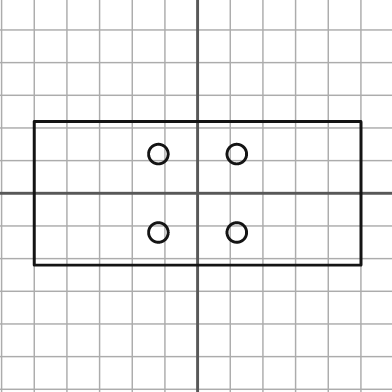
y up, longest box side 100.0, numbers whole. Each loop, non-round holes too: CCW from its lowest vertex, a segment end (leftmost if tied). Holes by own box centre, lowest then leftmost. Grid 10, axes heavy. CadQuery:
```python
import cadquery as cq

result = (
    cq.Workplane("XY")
    .moveTo(-50.0, -22.0)
    .lineTo(50.0, -22.0)
    .lineTo(50.0, 22.0)
    .lineTo(-50.0, 22.0)
    .close()
    .moveTo(-12.0, -12.0)
    .circle(3.0)
    .moveTo(12.0, -12.0)
    .circle(3.0)
    .moveTo(-12.0, 12.0)
    .circle(3.0)
    .moveTo(12.0, 12.0)
    .circle(3.0)
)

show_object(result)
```